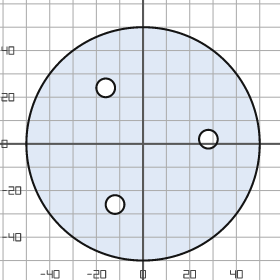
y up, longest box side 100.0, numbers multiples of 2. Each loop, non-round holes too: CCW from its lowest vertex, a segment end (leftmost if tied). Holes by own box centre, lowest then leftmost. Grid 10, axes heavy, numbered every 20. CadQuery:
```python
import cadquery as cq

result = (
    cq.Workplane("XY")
    .moveTo(0.0, 0.0)
    .circle(50.0)
    .moveTo(-12.0, -26.0)
    .circle(4.0)
    .moveTo(28.0, 2.0)
    .circle(4.0)
    .moveTo(-16.0, 24.0)
    .circle(4.0)
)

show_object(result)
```